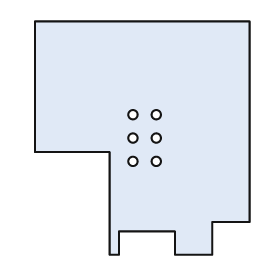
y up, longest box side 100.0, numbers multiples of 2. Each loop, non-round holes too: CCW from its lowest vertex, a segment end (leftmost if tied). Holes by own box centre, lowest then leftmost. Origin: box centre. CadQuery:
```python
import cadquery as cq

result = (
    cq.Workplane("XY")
    .moveTo(-14.0, -50.0)
    .lineTo(-10.0, -50.0)
    .lineTo(-10.0, -40.0)
    .lineTo(14.0, -40.0)
    .lineTo(14.0, -50.0)
    .lineTo(30.0, -50.0)
    .lineTo(30.0, -36.0)
    .lineTo(46.0, -36.0)
    .lineTo(46.0, 50.0)
    .lineTo(-46.0, 50.0)
    .lineTo(-46.0, -6.0)
    .lineTo(-14.0, -6.0)
    .close()
    .moveTo(-4.0, -10.0)
    .circle(2.0)
    .moveTo(6.0, -10.0)
    .circle(2.0)
    .moveTo(-4.0, 0.0)
    .circle(2.0)
    .moveTo(6.0, 0.0)
    .circle(2.0)
    .moveTo(-4.0, 10.0)
    .circle(2.0)
    .moveTo(6.0, 10.0)
    .circle(2.0)
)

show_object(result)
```